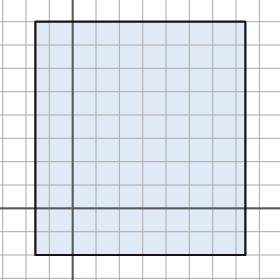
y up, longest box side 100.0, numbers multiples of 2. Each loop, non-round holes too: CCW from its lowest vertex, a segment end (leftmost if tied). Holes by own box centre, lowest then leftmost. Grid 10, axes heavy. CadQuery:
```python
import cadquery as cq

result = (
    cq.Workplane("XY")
    .moveTo(-16.0, -20.0)
    .lineTo(74.0, -20.0)
    .lineTo(74.0, 80.0)
    .lineTo(-16.0, 80.0)
    .close()
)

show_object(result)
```